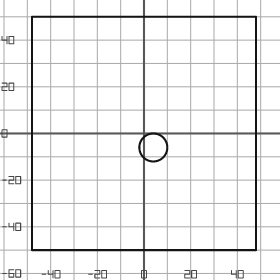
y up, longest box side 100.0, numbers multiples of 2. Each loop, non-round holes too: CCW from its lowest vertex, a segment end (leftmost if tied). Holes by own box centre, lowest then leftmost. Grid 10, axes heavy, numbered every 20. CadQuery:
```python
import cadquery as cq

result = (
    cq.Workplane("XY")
    .moveTo(-48.0, -50.0)
    .lineTo(48.0, -50.0)
    .lineTo(48.0, 50.0)
    .lineTo(-48.0, 50.0)
    .close()
    .moveTo(4.0, -6.0)
    .circle(6.0)
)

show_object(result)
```